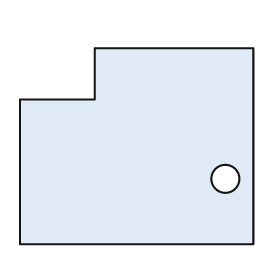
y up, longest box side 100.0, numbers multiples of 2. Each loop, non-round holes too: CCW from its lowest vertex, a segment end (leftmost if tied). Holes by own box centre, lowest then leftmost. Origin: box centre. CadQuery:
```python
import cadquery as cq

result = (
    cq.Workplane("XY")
    .moveTo(-50.0, -42.0)
    .lineTo(50.0, -42.0)
    .lineTo(50.0, 42.0)
    .lineTo(-18.0, 42.0)
    .lineTo(-18.0, 20.0)
    .lineTo(-50.0, 20.0)
    .close()
    .moveTo(38.0, -14.0)
    .circle(6.0)
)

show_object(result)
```